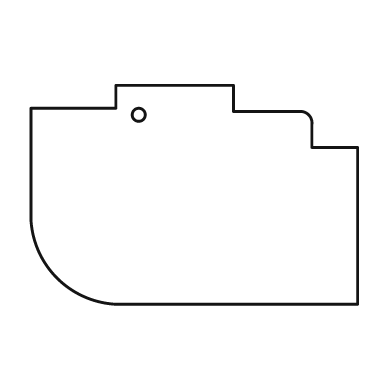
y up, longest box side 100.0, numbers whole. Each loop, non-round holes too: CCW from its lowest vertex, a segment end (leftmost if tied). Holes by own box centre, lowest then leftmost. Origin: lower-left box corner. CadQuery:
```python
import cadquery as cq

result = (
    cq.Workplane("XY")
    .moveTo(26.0, 0.0)
    .lineTo(100.0, 0.0)
    .lineTo(100.0, 48.0)
    .lineTo(86.0, 48.0)
    .lineTo(86.0, 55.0)
    .threePointArc((85.0, 58.0), (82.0, 59.0))
    .lineTo(62.0, 59.0)
    .lineTo(62.0, 67.0)
    .lineTo(26.0, 67.0)
    .lineTo(26.0, 60.0)
    .lineTo(0.0, 60.0)
    .lineTo(0.0, 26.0)
    .threePointArc((8.0, 8.0), (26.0, 0.0))
    .close()
    .moveTo(33.0, 58.0)
    .circle(2.0)
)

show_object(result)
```